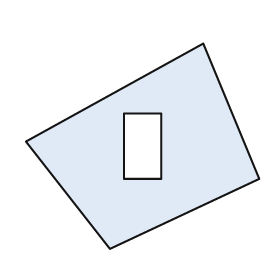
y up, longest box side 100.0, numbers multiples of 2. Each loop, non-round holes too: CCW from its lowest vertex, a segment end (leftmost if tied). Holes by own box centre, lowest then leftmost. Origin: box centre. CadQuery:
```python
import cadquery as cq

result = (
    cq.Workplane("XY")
    .moveTo(-14.0, -44.0)
    .lineTo(50.0, -14.0)
    .lineTo(26.0, 44.0)
    .lineTo(-50.0, 2.0)
    .close()
    .moveTo(-8.0, -14.0)
    .lineTo(8.0, -14.0)
    .lineTo(8.0, 14.0)
    .lineTo(-8.0, 14.0)
    .close()
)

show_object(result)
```